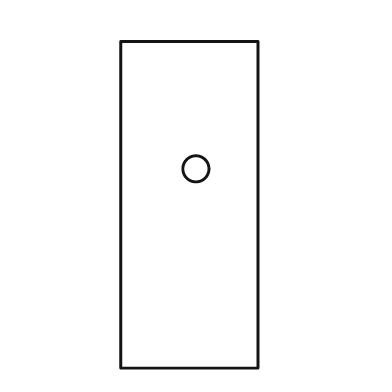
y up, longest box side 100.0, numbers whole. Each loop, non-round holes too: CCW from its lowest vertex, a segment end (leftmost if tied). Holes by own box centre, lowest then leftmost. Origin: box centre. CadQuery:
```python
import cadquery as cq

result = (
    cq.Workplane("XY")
    .moveTo(-21.0, -50.0)
    .lineTo(21.0, -50.0)
    .lineTo(21.0, 50.0)
    .lineTo(-21.0, 50.0)
    .close()
    .moveTo(2.0, 11.0)
    .circle(4.0)
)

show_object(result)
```